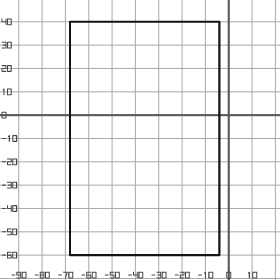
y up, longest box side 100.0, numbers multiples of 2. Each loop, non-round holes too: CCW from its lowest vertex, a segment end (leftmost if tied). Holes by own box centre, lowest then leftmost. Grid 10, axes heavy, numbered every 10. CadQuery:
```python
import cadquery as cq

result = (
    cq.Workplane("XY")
    .moveTo(-68.0, -60.0)
    .lineTo(-4.0, -60.0)
    .lineTo(-4.0, 40.0)
    .lineTo(-68.0, 40.0)
    .close()
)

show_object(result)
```